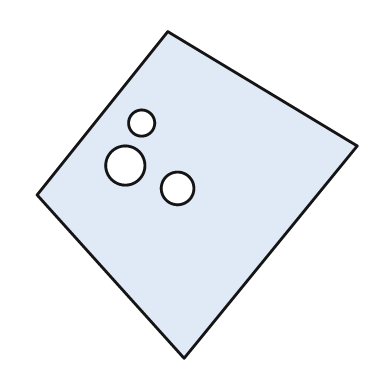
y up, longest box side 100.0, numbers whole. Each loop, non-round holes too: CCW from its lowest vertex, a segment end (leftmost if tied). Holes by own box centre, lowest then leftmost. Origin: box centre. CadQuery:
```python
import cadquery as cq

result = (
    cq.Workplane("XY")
    .moveTo(-4.0, -50.0)
    .lineTo(49.0, 15.0)
    .lineTo(-9.0, 50.0)
    .lineTo(-49.0, 0.0)
    .close()
    .moveTo(-6.0, 2.0)
    .circle(5.0)
    .moveTo(-22.0, 9.0)
    .circle(6.0)
    .moveTo(-17.0, 22.0)
    .circle(4.0)
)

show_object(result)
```